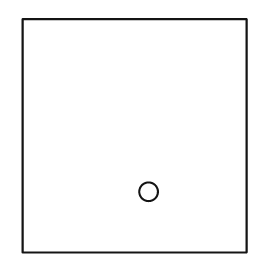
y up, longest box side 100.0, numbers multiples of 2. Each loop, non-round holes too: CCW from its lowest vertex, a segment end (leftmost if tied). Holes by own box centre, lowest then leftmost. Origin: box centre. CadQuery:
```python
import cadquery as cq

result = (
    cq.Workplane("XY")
    .moveTo(-48.0, -50.0)
    .lineTo(48.0, -50.0)
    .lineTo(48.0, 50.0)
    .lineTo(-48.0, 50.0)
    .close()
    .moveTo(6.0, -24.0)
    .circle(4.0)
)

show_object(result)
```